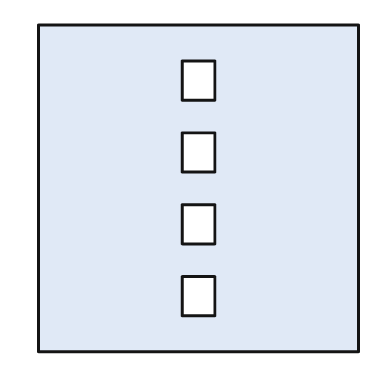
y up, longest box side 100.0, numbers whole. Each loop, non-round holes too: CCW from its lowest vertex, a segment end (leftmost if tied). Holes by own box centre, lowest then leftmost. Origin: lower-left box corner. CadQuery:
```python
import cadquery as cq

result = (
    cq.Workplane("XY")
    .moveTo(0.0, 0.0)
    .lineTo(98.0, 0.0)
    .lineTo(98.0, 100.0)
    .lineTo(0.0, 100.0)
    .close()
    .moveTo(44.0, 11.0)
    .lineTo(54.0, 11.0)
    .lineTo(54.0, 23.0)
    .lineTo(44.0, 23.0)
    .close()
    .moveTo(44.0, 33.0)
    .lineTo(54.0, 33.0)
    .lineTo(54.0, 45.0)
    .lineTo(44.0, 45.0)
    .close()
    .moveTo(44.0, 55.0)
    .lineTo(54.0, 55.0)
    .lineTo(54.0, 67.0)
    .lineTo(44.0, 67.0)
    .close()
    .moveTo(44.0, 77.0)
    .lineTo(54.0, 77.0)
    .lineTo(54.0, 89.0)
    .lineTo(44.0, 89.0)
    .close()
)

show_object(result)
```